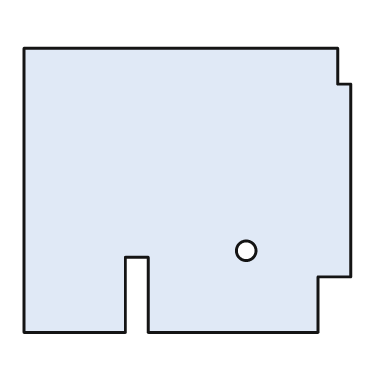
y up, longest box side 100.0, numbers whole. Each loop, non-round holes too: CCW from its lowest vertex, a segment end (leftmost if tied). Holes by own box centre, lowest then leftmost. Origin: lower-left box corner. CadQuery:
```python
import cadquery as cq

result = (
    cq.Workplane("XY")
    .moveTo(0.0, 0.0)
    .lineTo(31.0, 0.0)
    .lineTo(31.0, 23.0)
    .lineTo(38.0, 23.0)
    .lineTo(38.0, 0.0)
    .lineTo(90.0, 0.0)
    .lineTo(90.0, 17.0)
    .lineTo(100.0, 17.0)
    .lineTo(100.0, 76.0)
    .lineTo(96.0, 76.0)
    .lineTo(96.0, 87.0)
    .lineTo(0.0, 87.0)
    .close()
    .moveTo(68.0, 25.0)
    .circle(3.0)
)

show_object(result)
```